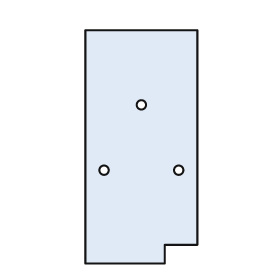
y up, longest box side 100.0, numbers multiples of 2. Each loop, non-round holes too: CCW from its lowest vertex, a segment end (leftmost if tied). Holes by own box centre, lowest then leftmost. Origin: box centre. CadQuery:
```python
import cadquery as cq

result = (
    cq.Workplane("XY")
    .moveTo(-24.0, -50.0)
    .lineTo(10.0, -50.0)
    .lineTo(10.0, -42.0)
    .lineTo(24.0, -42.0)
    .lineTo(24.0, 50.0)
    .lineTo(-24.0, 50.0)
    .close()
    .moveTo(-16.0, -10.0)
    .circle(2.0)
    .moveTo(16.0, -10.0)
    .circle(2.0)
    .moveTo(0.0, 18.0)
    .circle(2.0)
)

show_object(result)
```